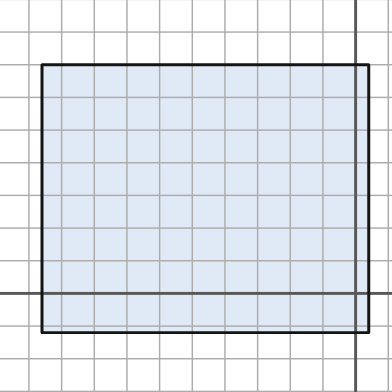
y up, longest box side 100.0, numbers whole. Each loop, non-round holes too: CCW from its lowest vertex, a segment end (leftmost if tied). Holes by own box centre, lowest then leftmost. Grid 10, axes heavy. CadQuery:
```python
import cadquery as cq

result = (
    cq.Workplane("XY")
    .moveTo(-96.0, -12.0)
    .lineTo(4.0, -12.0)
    .lineTo(4.0, 70.0)
    .lineTo(-96.0, 70.0)
    .close()
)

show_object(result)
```